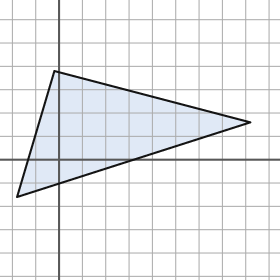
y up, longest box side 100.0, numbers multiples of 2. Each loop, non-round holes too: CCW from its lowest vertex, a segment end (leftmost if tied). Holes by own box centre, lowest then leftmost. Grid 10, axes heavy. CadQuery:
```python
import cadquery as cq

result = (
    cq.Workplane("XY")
    .moveTo(-18.0, -16.0)
    .lineTo(82.0, 16.0)
    .lineTo(-2.0, 38.0)
    .close()
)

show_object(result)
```